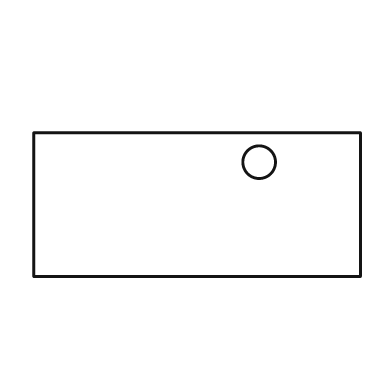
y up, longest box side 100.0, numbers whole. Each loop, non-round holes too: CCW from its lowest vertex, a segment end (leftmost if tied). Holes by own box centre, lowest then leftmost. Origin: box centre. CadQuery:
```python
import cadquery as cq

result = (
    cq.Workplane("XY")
    .moveTo(-50.0, -22.0)
    .lineTo(50.0, -22.0)
    .lineTo(50.0, 22.0)
    .lineTo(-50.0, 22.0)
    .close()
    .moveTo(19.0, 13.0)
    .circle(5.0)
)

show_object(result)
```